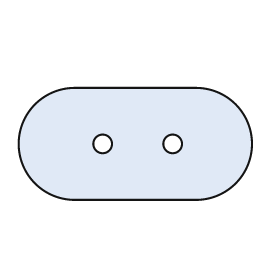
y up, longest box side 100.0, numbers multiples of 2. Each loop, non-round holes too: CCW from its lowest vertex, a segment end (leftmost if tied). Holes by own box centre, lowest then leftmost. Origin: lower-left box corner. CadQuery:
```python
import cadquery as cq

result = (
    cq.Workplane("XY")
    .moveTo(24.0, 0.0)
    .lineTo(76.0, 0.0)
    .threePointArc((100.0, 24.0), (76.0, 48.0))
    .lineTo(24.0, 48.0)
    .threePointArc((0.0, 24.0), (24.0, 0.0))
    .close()
    .moveTo(36.0, 24.0)
    .circle(4.0)
    .moveTo(66.0, 24.0)
    .circle(4.0)
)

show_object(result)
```